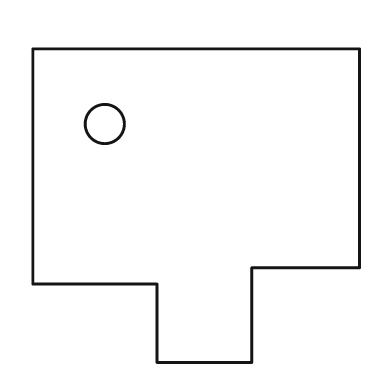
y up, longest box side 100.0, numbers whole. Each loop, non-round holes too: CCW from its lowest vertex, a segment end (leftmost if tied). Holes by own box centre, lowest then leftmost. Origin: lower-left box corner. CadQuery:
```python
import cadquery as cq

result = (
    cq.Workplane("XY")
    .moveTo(38.0, 0.0)
    .lineTo(67.0, 0.0)
    .lineTo(67.0, 29.0)
    .lineTo(100.0, 29.0)
    .lineTo(100.0, 96.0)
    .lineTo(0.0, 96.0)
    .lineTo(0.0, 24.0)
    .lineTo(38.0, 24.0)
    .close()
    .moveTo(22.0, 73.0)
    .circle(6.0)
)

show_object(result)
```